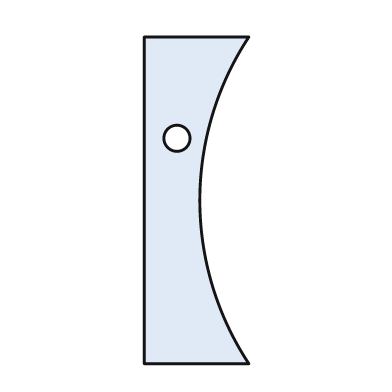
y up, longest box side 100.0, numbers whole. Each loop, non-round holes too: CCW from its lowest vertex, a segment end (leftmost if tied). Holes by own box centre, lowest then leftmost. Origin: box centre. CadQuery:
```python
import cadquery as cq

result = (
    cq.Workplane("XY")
    .moveTo(-16.0, -50.0)
    .lineTo(16.0, -50.0)
    .threePointArc((1.0, 0.0), (16.0, 50.0))
    .lineTo(-16.0, 50.0)
    .close()
    .moveTo(-6.0, 19.0)
    .circle(4.0)
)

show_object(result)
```